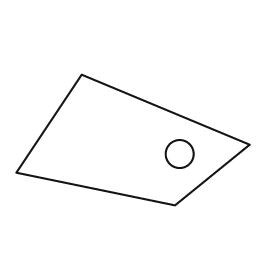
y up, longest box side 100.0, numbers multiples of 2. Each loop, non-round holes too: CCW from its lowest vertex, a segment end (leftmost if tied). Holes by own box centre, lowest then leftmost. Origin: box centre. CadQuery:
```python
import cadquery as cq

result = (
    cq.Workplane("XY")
    .moveTo(18.0, -28.0)
    .lineTo(50.0, -2.0)
    .lineTo(-22.0, 28.0)
    .lineTo(-50.0, -14.0)
    .close()
    .moveTo(20.0, -6.0)
    .circle(6.0)
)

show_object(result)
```